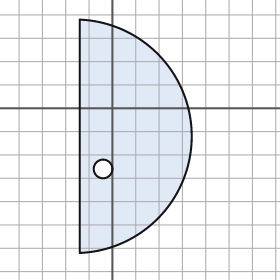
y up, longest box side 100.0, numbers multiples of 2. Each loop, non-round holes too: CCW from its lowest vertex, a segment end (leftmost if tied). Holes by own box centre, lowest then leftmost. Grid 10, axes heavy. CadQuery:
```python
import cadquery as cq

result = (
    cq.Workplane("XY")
    .moveTo(-14.0, -62.0)
    .threePointArc((34.0, -12.0), (-14.0, 38.0))
    .close()
    .moveTo(-4.0, -26.0)
    .circle(4.0)
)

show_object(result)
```